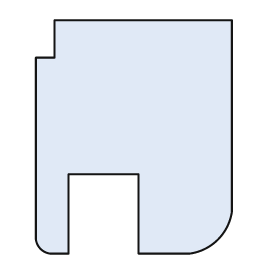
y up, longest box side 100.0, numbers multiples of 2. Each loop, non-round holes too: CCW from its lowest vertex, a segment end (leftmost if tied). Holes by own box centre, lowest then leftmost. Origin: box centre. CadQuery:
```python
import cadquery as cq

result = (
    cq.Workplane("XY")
    .moveTo(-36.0, -50.0)
    .lineTo(-28.0, -50.0)
    .lineTo(-28.0, -16.0)
    .lineTo(2.0, -16.0)
    .lineTo(2.0, -50.0)
    .lineTo(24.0, -50.0)
    .threePointArc((36.0, -44.0), (42.0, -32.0))
    .lineTo(42.0, 50.0)
    .lineTo(-34.0, 50.0)
    .lineTo(-34.0, 34.0)
    .lineTo(-42.0, 34.0)
    .lineTo(-42.0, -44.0)
    .threePointArc((-40.0, -48.0), (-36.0, -50.0))
    .close()
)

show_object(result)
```